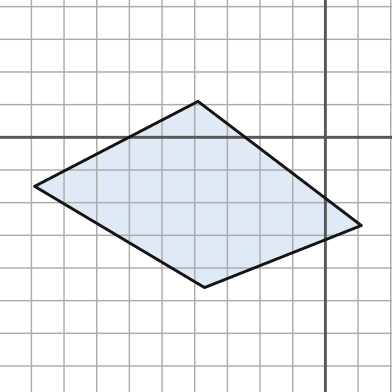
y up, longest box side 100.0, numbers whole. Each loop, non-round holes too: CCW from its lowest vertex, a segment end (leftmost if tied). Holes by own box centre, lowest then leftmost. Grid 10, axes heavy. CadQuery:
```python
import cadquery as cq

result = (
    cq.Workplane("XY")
    .moveTo(-37.0, -46.0)
    .lineTo(11.0, -27.0)
    .lineTo(-39.0, 11.0)
    .lineTo(-89.0, -15.0)
    .close()
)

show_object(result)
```